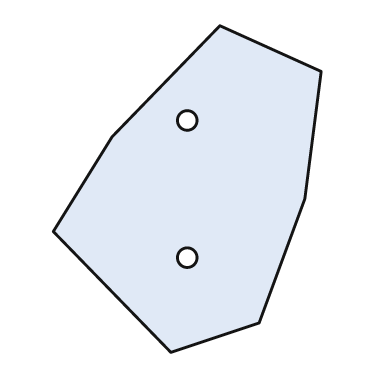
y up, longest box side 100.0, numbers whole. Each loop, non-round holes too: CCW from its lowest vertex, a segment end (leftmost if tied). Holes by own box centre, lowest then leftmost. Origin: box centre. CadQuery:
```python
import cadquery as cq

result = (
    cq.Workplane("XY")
    .moveTo(-5.0, -50.0)
    .lineTo(22.0, -41.0)
    .lineTo(36.0, -3.0)
    .lineTo(41.0, 36.0)
    .lineTo(10.0, 50.0)
    .lineTo(-23.0, 16.0)
    .lineTo(-41.0, -13.0)
    .close()
    .moveTo(0.0, -21.0)
    .circle(3.0)
    .moveTo(0.0, 21.0)
    .circle(3.0)
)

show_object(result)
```